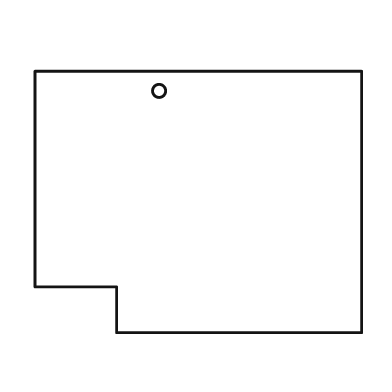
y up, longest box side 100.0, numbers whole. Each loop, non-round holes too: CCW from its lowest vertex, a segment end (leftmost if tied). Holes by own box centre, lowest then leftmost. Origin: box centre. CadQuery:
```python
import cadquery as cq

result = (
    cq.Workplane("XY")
    .moveTo(-25.0, -40.0)
    .lineTo(50.0, -40.0)
    .lineTo(50.0, 40.0)
    .lineTo(-50.0, 40.0)
    .lineTo(-50.0, -26.0)
    .lineTo(-25.0, -26.0)
    .close()
    .moveTo(-12.0, 34.0)
    .circle(2.0)
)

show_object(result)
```